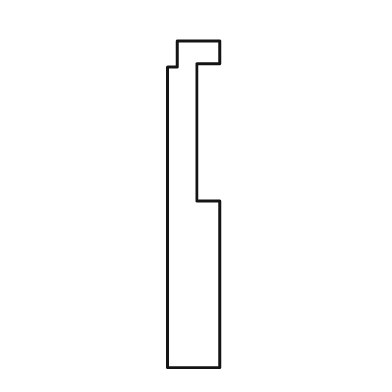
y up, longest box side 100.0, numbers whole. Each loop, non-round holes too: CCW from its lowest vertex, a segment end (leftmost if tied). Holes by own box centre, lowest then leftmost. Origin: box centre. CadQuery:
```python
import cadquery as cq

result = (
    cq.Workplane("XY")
    .moveTo(-8.0, -50.0)
    .lineTo(8.0, -50.0)
    .lineTo(8.0, 1.0)
    .lineTo(1.0, 1.0)
    .lineTo(1.0, 43.0)
    .lineTo(8.0, 43.0)
    .lineTo(8.0, 50.0)
    .lineTo(-5.0, 50.0)
    .lineTo(-5.0, 42.0)
    .lineTo(-8.0, 42.0)
    .close()
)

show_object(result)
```